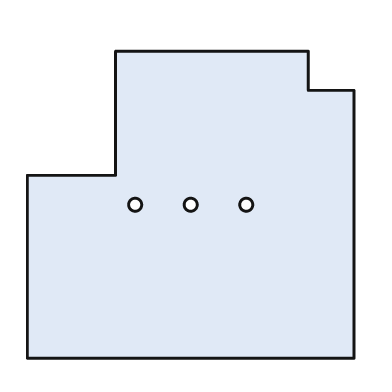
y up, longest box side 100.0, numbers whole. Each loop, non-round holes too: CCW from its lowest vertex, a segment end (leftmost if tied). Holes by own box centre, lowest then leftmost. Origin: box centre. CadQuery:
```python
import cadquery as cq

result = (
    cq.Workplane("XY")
    .moveTo(-50.0, -47.0)
    .lineTo(50.0, -47.0)
    .lineTo(50.0, 35.0)
    .lineTo(36.0, 35.0)
    .lineTo(36.0, 47.0)
    .lineTo(-23.0, 47.0)
    .lineTo(-23.0, 9.0)
    .lineTo(-50.0, 9.0)
    .close()
    .moveTo(-17.0, 0.0)
    .circle(2.0)
    .moveTo(0.0, 0.0)
    .circle(2.0)
    .moveTo(17.0, 0.0)
    .circle(2.0)
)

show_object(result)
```